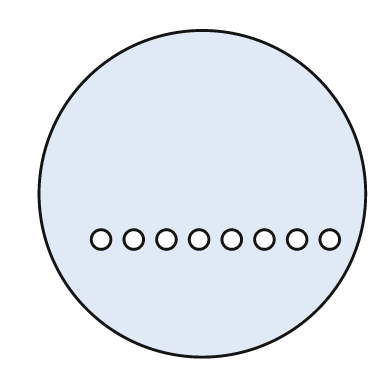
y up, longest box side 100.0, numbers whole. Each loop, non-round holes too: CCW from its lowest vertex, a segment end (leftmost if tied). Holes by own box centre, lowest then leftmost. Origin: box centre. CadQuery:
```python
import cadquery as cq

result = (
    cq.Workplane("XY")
    .moveTo(0.0, 0.0)
    .circle(50.0)
    .moveTo(-31.0, -14.0)
    .circle(3.0)
    .moveTo(-21.0, -14.0)
    .circle(3.0)
    .moveTo(-11.0, -14.0)
    .circle(3.0)
    .moveTo(-1.0, -14.0)
    .circle(3.0)
    .moveTo(9.0, -14.0)
    .circle(3.0)
    .moveTo(19.0, -14.0)
    .circle(3.0)
    .moveTo(29.0, -14.0)
    .circle(3.0)
    .moveTo(39.0, -14.0)
    .circle(3.0)
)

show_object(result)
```